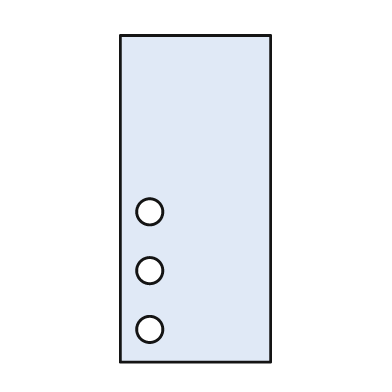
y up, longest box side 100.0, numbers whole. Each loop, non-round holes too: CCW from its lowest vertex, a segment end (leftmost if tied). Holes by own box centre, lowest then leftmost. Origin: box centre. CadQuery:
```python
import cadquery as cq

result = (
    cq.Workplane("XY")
    .moveTo(-23.0, -50.0)
    .lineTo(23.0, -50.0)
    .lineTo(23.0, 50.0)
    .lineTo(-23.0, 50.0)
    .close()
    .moveTo(-14.0, -40.0)
    .circle(4.0)
    .moveTo(-14.0, -22.0)
    .circle(4.0)
    .moveTo(-14.0, -4.0)
    .circle(4.0)
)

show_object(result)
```